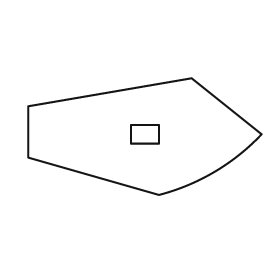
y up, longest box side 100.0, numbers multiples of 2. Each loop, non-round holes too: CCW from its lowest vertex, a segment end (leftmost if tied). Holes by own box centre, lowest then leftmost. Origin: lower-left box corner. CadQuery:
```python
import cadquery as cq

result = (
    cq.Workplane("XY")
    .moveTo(56.0, 0.0)
    .threePointArc((80.0, 10.0), (100.0, 26.0))
    .lineTo(70.0, 50.0)
    .lineTo(0.0, 38.0)
    .lineTo(0.0, 16.0)
    .close()
    .moveTo(44.0, 22.0)
    .lineTo(56.0, 22.0)
    .lineTo(56.0, 30.0)
    .lineTo(44.0, 30.0)
    .close()
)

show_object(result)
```